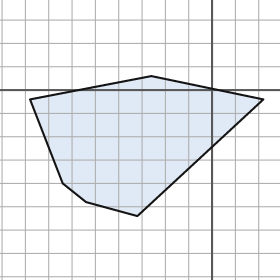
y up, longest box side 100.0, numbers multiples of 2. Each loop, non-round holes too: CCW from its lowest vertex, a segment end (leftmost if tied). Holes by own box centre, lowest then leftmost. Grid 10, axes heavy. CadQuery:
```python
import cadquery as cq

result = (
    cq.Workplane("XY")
    .moveTo(-32.0, -54.0)
    .lineTo(22.0, -4.0)
    .lineTo(-26.0, 6.0)
    .lineTo(-78.0, -4.0)
    .lineTo(-64.0, -40.0)
    .lineTo(-54.0, -48.0)
    .close()
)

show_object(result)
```